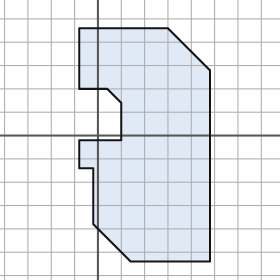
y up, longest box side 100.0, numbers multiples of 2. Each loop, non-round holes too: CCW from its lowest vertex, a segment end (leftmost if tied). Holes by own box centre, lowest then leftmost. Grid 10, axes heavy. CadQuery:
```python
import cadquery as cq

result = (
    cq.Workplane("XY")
    .moveTo(14.0, -54.0)
    .lineTo(48.0, -54.0)
    .lineTo(48.0, 28.0)
    .lineTo(30.0, 46.0)
    .lineTo(-8.0, 46.0)
    .lineTo(-8.0, 20.0)
    .lineTo(4.0, 20.0)
    .lineTo(10.0, 14.0)
    .lineTo(10.0, -2.0)
    .lineTo(-8.0, -2.0)
    .lineTo(-8.0, -14.0)
    .lineTo(-2.0, -14.0)
    .lineTo(-2.0, -38.0)
    .close()
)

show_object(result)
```